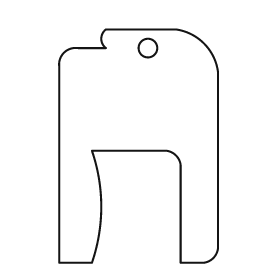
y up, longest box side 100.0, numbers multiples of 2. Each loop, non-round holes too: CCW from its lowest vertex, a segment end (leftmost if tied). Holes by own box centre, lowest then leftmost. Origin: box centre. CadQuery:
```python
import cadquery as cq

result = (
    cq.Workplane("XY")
    .moveTo(-34.0, -50.0)
    .lineTo(-20.0, -50.0)
    .threePointArc((-16.0, -26.0), (-20.0, -2.0))
    .lineTo(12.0, -2.0)
    .threePointArc((16.0, -4.0), (18.0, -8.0))
    .lineTo(18.0, -50.0)
    .lineTo(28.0, -50.0)
    .threePointArc((32.0, -48.0), (34.0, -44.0))
    .lineTo(34.0, 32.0)
    .threePointArc((28.0, 44.0), (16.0, 50.0))
    .lineTo(-14.0, 50.0)
    .threePointArc((-16.0, 46.0), (-14.0, 42.0))
    .lineTo(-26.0, 42.0)
    .threePointArc((-32.0, 40.0), (-34.0, 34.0))
    .close()
    .moveTo(4.0, 42.0)
    .circle(4.0)
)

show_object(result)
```